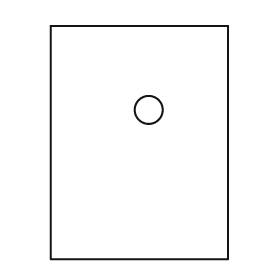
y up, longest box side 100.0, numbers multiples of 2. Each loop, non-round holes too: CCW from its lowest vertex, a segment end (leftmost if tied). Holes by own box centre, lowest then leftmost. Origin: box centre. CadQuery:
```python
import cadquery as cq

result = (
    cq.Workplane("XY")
    .moveTo(-38.0, -50.0)
    .lineTo(38.0, -50.0)
    .lineTo(38.0, 50.0)
    .lineTo(-38.0, 50.0)
    .close()
    .moveTo(4.0, 14.0)
    .circle(6.0)
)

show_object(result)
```